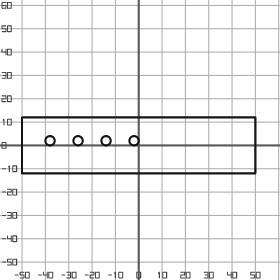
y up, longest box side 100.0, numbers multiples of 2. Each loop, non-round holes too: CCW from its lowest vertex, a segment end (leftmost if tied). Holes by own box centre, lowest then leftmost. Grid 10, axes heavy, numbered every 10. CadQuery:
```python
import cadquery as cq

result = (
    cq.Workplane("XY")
    .moveTo(-50.0, -12.0)
    .lineTo(50.0, -12.0)
    .lineTo(50.0, 12.0)
    .lineTo(-50.0, 12.0)
    .close()
    .moveTo(-38.0, 2.0)
    .circle(2.0)
    .moveTo(-26.0, 2.0)
    .circle(2.0)
    .moveTo(-14.0, 2.0)
    .circle(2.0)
    .moveTo(-2.0, 2.0)
    .circle(2.0)
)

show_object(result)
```